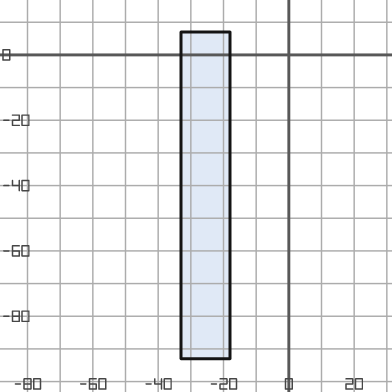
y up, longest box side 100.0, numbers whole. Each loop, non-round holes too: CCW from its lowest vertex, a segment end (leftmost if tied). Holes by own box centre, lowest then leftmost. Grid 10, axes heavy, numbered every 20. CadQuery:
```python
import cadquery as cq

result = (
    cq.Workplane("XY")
    .moveTo(-33.0, -93.0)
    .lineTo(-18.0, -93.0)
    .lineTo(-18.0, 7.0)
    .lineTo(-33.0, 7.0)
    .close()
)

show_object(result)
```